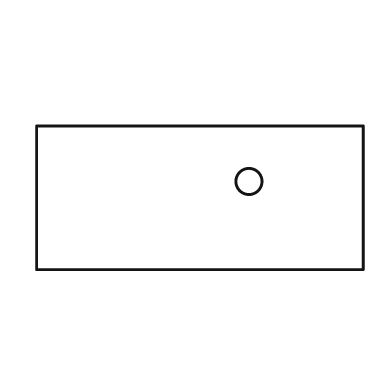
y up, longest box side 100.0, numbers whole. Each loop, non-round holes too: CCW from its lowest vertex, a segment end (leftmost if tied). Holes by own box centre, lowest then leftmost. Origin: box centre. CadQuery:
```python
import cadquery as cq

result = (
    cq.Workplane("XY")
    .moveTo(-50.0, -22.0)
    .lineTo(50.0, -22.0)
    .lineTo(50.0, 22.0)
    .lineTo(-50.0, 22.0)
    .close()
    .moveTo(15.0, 5.0)
    .circle(4.0)
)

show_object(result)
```